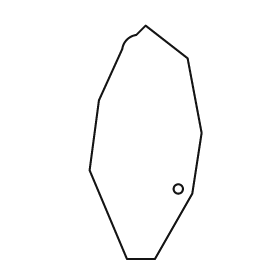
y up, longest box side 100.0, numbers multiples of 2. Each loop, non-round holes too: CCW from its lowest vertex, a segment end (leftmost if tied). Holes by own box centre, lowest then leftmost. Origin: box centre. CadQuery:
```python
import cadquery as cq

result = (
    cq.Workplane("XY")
    .moveTo(-8.0, -50.0)
    .lineTo(4.0, -50.0)
    .lineTo(20.0, -22.0)
    .lineTo(24.0, 4.0)
    .lineTo(18.0, 36.0)
    .lineTo(0.0, 50.0)
    .lineTo(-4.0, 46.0)
    .threePointArc((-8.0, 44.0), (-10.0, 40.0))
    .lineTo(-20.0, 18.0)
    .lineTo(-24.0, -12.0)
    .close()
    .moveTo(14.0, -20.0)
    .circle(2.0)
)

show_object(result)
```